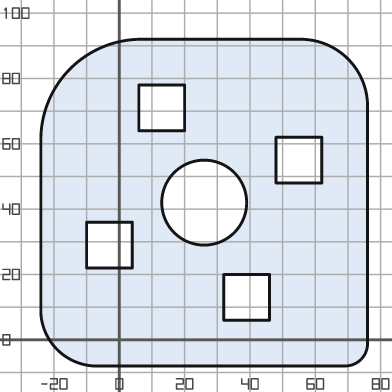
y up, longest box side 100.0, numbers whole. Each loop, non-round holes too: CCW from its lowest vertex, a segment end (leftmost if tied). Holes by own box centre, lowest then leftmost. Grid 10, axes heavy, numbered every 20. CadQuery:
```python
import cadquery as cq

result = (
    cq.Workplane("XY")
    .moveTo(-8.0, -8.0)
    .lineTo(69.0, -8.0)
    .threePointArc((74.0, -6.0), (76.0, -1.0))
    .lineTo(76.0, 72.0)
    .threePointArc((70.0, 86.0), (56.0, 92.0))
    .lineTo(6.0, 92.0)
    .threePointArc((-15.0, 83.0), (-24.0, 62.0))
    .lineTo(-24.0, 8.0)
    .threePointArc((-19.0, -3.0), (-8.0, -8.0))
    .close()
    .moveTo(32.0, 6.0)
    .lineTo(46.0, 6.0)
    .lineTo(46.0, 20.0)
    .lineTo(32.0, 20.0)
    .close()
    .moveTo(-10.0, 22.0)
    .lineTo(4.0, 22.0)
    .lineTo(4.0, 36.0)
    .lineTo(-10.0, 36.0)
    .close()
    .moveTo(26.0, 42.0)
    .circle(13.0)
    .moveTo(48.0, 48.0)
    .lineTo(62.0, 48.0)
    .lineTo(62.0, 62.0)
    .lineTo(48.0, 62.0)
    .close()
    .moveTo(6.0, 64.0)
    .lineTo(20.0, 64.0)
    .lineTo(20.0, 78.0)
    .lineTo(6.0, 78.0)
    .close()
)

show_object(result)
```